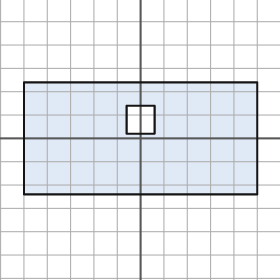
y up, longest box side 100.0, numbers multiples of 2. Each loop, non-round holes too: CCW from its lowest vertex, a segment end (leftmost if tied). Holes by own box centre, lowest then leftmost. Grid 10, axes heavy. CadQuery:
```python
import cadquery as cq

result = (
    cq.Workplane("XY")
    .moveTo(-50.0, -24.0)
    .lineTo(50.0, -24.0)
    .lineTo(50.0, 24.0)
    .lineTo(-50.0, 24.0)
    .close()
    .moveTo(-6.0, 2.0)
    .lineTo(6.0, 2.0)
    .lineTo(6.0, 14.0)
    .lineTo(-6.0, 14.0)
    .close()
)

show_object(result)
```